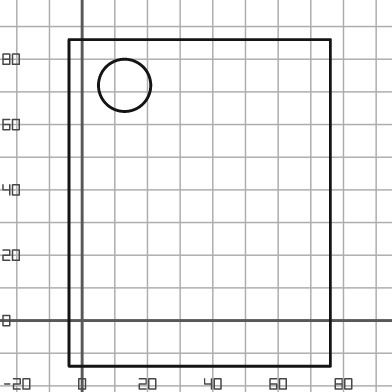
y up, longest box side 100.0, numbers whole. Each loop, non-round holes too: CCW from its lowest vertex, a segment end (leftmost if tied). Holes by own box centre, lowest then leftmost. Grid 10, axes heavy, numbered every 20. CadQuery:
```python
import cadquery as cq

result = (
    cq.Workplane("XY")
    .moveTo(-4.0, -14.0)
    .lineTo(76.0, -14.0)
    .lineTo(76.0, 86.0)
    .lineTo(-4.0, 86.0)
    .close()
    .moveTo(13.0, 72.0)
    .circle(8.0)
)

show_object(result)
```